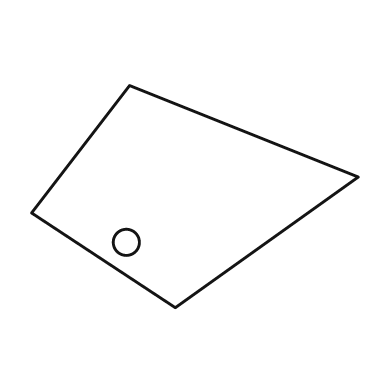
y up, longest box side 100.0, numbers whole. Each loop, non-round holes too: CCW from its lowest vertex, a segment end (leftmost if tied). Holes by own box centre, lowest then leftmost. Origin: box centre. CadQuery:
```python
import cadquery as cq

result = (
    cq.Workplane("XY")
    .moveTo(-6.0, -34.0)
    .lineTo(50.0, 6.0)
    .lineTo(-20.0, 34.0)
    .lineTo(-50.0, -5.0)
    .close()
    .moveTo(-21.0, -14.0)
    .circle(4.0)
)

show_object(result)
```